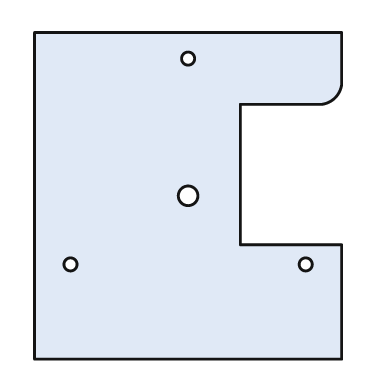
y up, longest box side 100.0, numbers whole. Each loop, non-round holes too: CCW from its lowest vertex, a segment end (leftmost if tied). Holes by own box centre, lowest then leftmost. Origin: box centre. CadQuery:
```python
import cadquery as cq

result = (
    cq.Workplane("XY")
    .moveTo(-47.0, -50.0)
    .lineTo(47.0, -50.0)
    .lineTo(47.0, -15.0)
    .lineTo(16.0, -15.0)
    .lineTo(16.0, 28.0)
    .lineTo(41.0, 28.0)
    .threePointArc((45.0, 30.0), (47.0, 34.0))
    .lineTo(47.0, 50.0)
    .lineTo(-47.0, 50.0)
    .close()
    .moveTo(-36.0, -21.0)
    .circle(2.0)
    .moveTo(36.0, -21.0)
    .circle(2.0)
    .moveTo(0.0, 0.0)
    .circle(3.0)
    .moveTo(0.0, 42.0)
    .circle(2.0)
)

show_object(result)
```